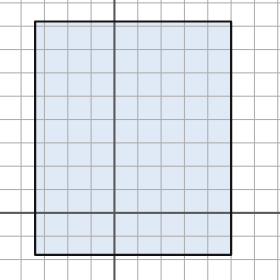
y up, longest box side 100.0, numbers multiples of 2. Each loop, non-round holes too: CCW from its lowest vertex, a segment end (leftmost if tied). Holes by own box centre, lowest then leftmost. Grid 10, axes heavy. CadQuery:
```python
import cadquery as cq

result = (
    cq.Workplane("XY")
    .moveTo(-34.0, -18.0)
    .lineTo(50.0, -18.0)
    .lineTo(50.0, 82.0)
    .lineTo(-34.0, 82.0)
    .close()
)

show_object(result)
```